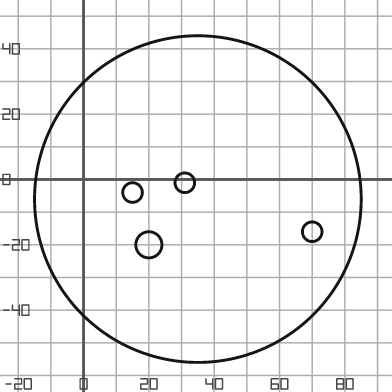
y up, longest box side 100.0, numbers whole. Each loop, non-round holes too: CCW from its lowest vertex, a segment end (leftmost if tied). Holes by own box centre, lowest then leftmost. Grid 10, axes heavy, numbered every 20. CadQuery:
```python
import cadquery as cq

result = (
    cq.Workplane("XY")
    .moveTo(35.0, -6.0)
    .circle(50.0)
    .moveTo(20.0, -20.0)
    .circle(4.0)
    .moveTo(70.0, -16.0)
    .circle(3.0)
    .moveTo(15.0, -4.0)
    .circle(3.0)
    .moveTo(31.0, -1.0)
    .circle(3.0)
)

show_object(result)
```